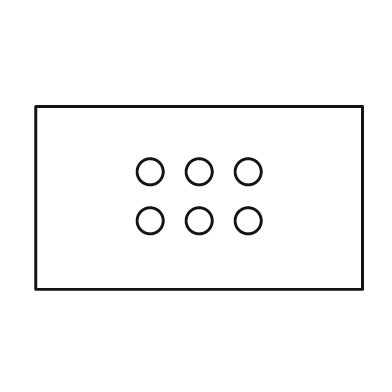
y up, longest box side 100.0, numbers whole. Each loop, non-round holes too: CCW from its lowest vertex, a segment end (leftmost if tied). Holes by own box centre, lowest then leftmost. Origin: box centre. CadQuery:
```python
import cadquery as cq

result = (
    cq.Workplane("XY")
    .moveTo(-50.0, -28.0)
    .lineTo(50.0, -28.0)
    .lineTo(50.0, 28.0)
    .lineTo(-50.0, 28.0)
    .close()
    .moveTo(-15.0, -7.0)
    .circle(4.0)
    .moveTo(0.0, -7.0)
    .circle(4.0)
    .moveTo(15.0, -7.0)
    .circle(4.0)
    .moveTo(-15.0, 8.0)
    .circle(4.0)
    .moveTo(0.0, 8.0)
    .circle(4.0)
    .moveTo(15.0, 8.0)
    .circle(4.0)
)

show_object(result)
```